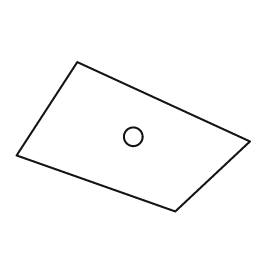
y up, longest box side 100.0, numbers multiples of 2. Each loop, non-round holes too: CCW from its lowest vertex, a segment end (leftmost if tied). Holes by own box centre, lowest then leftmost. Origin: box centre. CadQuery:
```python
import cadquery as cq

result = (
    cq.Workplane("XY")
    .moveTo(18.0, -32.0)
    .lineTo(50.0, -2.0)
    .lineTo(-24.0, 32.0)
    .lineTo(-50.0, -8.0)
    .close()
    .moveTo(0.0, 0.0)
    .circle(4.0)
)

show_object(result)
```